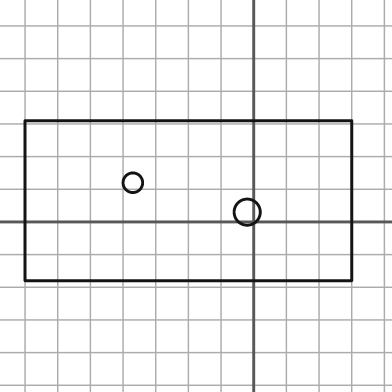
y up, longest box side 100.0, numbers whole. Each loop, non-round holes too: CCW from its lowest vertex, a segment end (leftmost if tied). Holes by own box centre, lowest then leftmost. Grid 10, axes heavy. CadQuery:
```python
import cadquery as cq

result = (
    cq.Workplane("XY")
    .moveTo(-70.0, -18.0)
    .lineTo(30.0, -18.0)
    .lineTo(30.0, 31.0)
    .lineTo(-70.0, 31.0)
    .close()
    .moveTo(-2.0, 3.0)
    .circle(4.0)
    .moveTo(-37.0, 12.0)
    .circle(3.0)
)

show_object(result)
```